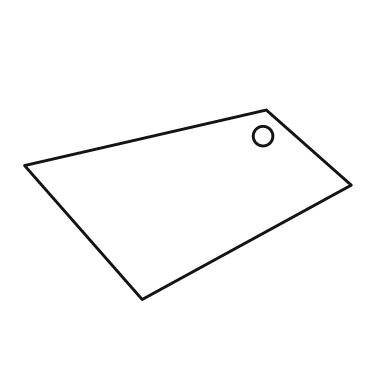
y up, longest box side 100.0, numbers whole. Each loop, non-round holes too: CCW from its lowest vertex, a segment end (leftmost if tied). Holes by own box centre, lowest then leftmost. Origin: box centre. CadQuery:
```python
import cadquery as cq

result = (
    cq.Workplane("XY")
    .moveTo(-14.0, -29.0)
    .lineTo(50.0, 6.0)
    .lineTo(24.0, 29.0)
    .lineTo(-50.0, 12.0)
    .close()
    .moveTo(23.0, 21.0)
    .circle(3.0)
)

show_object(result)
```